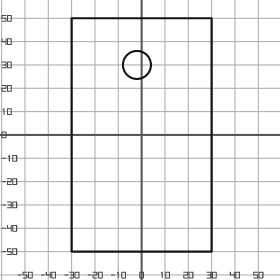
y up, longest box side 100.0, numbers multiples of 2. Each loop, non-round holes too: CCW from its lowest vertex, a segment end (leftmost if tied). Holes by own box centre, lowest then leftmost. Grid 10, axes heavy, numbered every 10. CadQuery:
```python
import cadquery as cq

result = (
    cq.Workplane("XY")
    .moveTo(-30.0, -50.0)
    .lineTo(30.0, -50.0)
    .lineTo(30.0, 50.0)
    .lineTo(-30.0, 50.0)
    .close()
    .moveTo(-2.0, 30.0)
    .circle(6.0)
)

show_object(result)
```